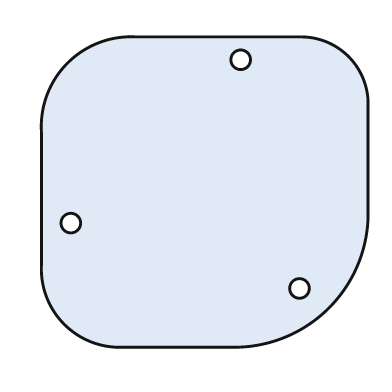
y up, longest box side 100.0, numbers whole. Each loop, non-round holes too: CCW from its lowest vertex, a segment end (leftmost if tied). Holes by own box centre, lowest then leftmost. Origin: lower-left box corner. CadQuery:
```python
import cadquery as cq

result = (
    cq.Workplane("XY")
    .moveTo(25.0, 0.0)
    .lineTo(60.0, 0.0)
    .threePointArc((88.0, 12.0), (100.0, 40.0))
    .lineTo(100.0, 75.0)
    .threePointArc((94.0, 89.0), (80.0, 95.0))
    .lineTo(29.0, 95.0)
    .threePointArc((8.0, 87.0), (0.0, 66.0))
    .lineTo(0.0, 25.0)
    .threePointArc((7.0, 7.0), (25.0, 0.0))
    .close()
    .moveTo(79.0, 18.0)
    .circle(3.0)
    .moveTo(9.0, 38.0)
    .circle(3.0)
    .moveTo(61.0, 88.0)
    .circle(3.0)
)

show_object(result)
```